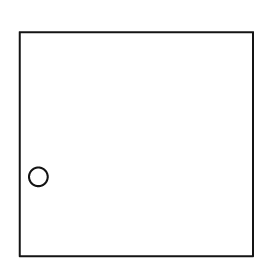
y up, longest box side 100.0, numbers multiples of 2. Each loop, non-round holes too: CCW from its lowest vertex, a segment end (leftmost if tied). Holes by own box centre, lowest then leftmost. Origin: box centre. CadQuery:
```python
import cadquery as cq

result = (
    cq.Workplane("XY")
    .moveTo(-50.0, -48.0)
    .lineTo(50.0, -48.0)
    .lineTo(50.0, 48.0)
    .lineTo(-50.0, 48.0)
    .close()
    .moveTo(-42.0, -14.0)
    .circle(4.0)
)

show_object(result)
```